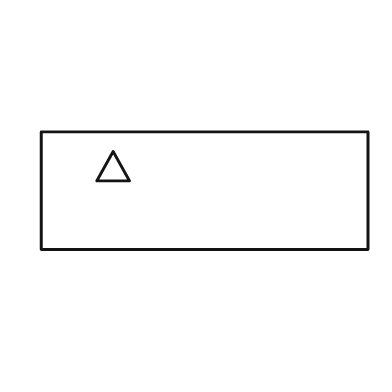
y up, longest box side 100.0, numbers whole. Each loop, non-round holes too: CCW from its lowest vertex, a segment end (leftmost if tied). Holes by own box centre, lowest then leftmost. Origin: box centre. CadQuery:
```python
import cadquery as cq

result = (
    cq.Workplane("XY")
    .moveTo(-50.0, -18.0)
    .lineTo(50.0, -18.0)
    .lineTo(50.0, 18.0)
    .lineTo(-50.0, 18.0)
    .close()
    .moveTo(-33.0, 3.0)
    .lineTo(-23.0, 3.0)
    .lineTo(-28.0, 12.0)
    .close()
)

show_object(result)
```